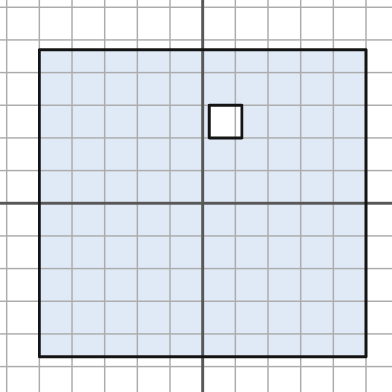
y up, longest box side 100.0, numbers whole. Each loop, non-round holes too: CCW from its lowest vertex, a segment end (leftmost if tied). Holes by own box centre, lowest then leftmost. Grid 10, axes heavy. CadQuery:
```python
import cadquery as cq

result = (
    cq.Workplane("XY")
    .moveTo(-50.0, -47.0)
    .lineTo(50.0, -47.0)
    .lineTo(50.0, 47.0)
    .lineTo(-50.0, 47.0)
    .close()
    .moveTo(2.0, 20.0)
    .lineTo(12.0, 20.0)
    .lineTo(12.0, 30.0)
    .lineTo(2.0, 30.0)
    .close()
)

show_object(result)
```